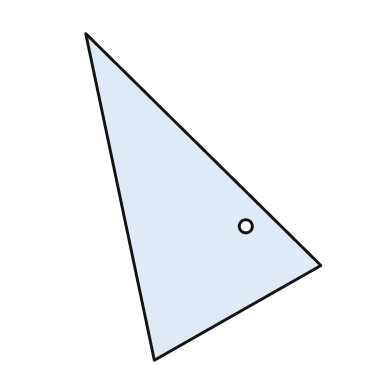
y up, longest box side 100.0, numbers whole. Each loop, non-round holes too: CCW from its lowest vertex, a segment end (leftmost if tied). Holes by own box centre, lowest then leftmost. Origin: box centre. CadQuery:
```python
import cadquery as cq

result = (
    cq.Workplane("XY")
    .moveTo(-15.0, -50.0)
    .lineTo(36.0, -21.0)
    .lineTo(-36.0, 50.0)
    .close()
    .moveTo(13.0, -9.0)
    .circle(2.0)
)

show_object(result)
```